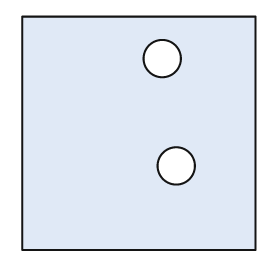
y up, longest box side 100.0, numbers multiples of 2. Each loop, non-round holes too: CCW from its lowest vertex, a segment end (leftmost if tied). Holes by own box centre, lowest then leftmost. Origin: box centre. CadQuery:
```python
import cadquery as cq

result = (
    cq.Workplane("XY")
    .moveTo(-50.0, -50.0)
    .lineTo(50.0, -50.0)
    .lineTo(50.0, 50.0)
    .lineTo(-50.0, 50.0)
    .close()
    .moveTo(16.0, -14.0)
    .circle(8.0)
    .moveTo(10.0, 32.0)
    .circle(8.0)
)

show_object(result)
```